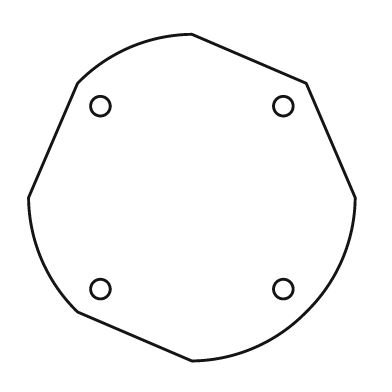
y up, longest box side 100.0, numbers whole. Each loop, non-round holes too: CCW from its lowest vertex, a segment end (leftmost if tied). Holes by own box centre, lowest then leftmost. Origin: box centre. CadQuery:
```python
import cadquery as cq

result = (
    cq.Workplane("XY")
    .moveTo(0.0, -50.0)
    .threePointArc((19.0, -46.0), (35.0, -35.0))
    .threePointArc((46.0, -19.0), (50.0, 0.0))
    .lineTo(35.0, 35.0)
    .lineTo(0.0, 50.0)
    .threePointArc((-19.0, 46.0), (-35.0, 35.0))
    .lineTo(-50.0, 0.0)
    .threePointArc((-46.0, -19.0), (-35.0, -35.0))
    .close()
    .moveTo(-28.0, -28.0)
    .circle(3.0)
    .moveTo(28.0, -28.0)
    .circle(3.0)
    .moveTo(-28.0, 28.0)
    .circle(3.0)
    .moveTo(28.0, 28.0)
    .circle(3.0)
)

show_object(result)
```